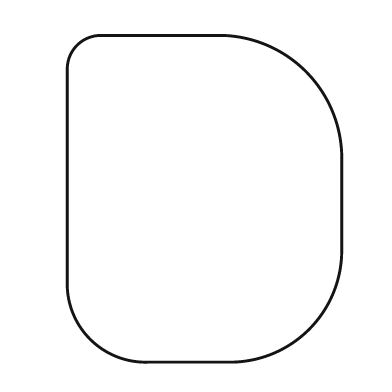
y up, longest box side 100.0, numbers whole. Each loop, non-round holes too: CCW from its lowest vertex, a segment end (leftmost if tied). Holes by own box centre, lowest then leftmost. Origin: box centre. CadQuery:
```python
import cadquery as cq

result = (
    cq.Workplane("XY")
    .moveTo(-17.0, -50.0)
    .lineTo(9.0, -50.0)
    .threePointArc((32.0, -40.0), (42.0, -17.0))
    .lineTo(42.0, 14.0)
    .threePointArc((31.0, 39.0), (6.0, 50.0))
    .lineTo(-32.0, 50.0)
    .threePointArc((-39.0, 47.0), (-42.0, 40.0))
    .lineTo(-42.0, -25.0)
    .threePointArc((-35.0, -43.0), (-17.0, -50.0))
    .close()
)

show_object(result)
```